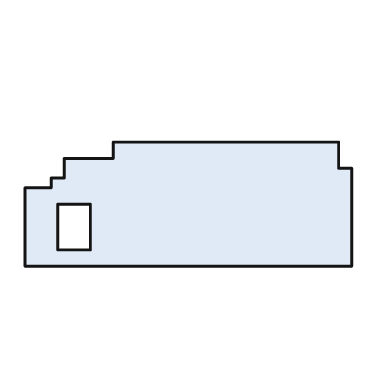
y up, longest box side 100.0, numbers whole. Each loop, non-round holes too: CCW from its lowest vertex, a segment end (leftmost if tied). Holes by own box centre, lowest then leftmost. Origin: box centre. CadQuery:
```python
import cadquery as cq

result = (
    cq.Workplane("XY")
    .moveTo(-50.0, -19.0)
    .lineTo(50.0, -19.0)
    .lineTo(50.0, 11.0)
    .lineTo(46.0, 11.0)
    .lineTo(46.0, 19.0)
    .lineTo(-23.0, 19.0)
    .lineTo(-23.0, 14.0)
    .lineTo(-38.0, 14.0)
    .lineTo(-38.0, 8.0)
    .lineTo(-42.0, 8.0)
    .lineTo(-42.0, 5.0)
    .lineTo(-50.0, 5.0)
    .close()
    .moveTo(-40.0, -14.0)
    .lineTo(-30.0, -14.0)
    .lineTo(-30.0, 0.0)
    .lineTo(-40.0, 0.0)
    .close()
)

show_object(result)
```